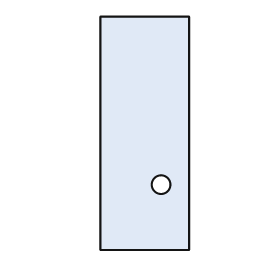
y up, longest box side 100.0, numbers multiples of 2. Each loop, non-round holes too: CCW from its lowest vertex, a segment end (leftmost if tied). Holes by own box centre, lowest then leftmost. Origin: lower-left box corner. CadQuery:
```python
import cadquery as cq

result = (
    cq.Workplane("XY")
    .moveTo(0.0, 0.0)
    .lineTo(38.0, 0.0)
    .lineTo(38.0, 100.0)
    .lineTo(0.0, 100.0)
    .close()
    .moveTo(26.0, 28.0)
    .circle(4.0)
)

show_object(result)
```